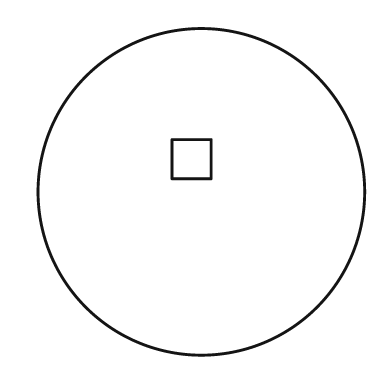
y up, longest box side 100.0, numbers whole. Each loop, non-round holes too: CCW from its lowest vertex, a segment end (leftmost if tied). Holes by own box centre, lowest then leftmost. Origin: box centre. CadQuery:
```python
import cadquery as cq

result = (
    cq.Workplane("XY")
    .moveTo(0.0, 0.0)
    .circle(50.0)
    .moveTo(-9.0, 4.0)
    .lineTo(3.0, 4.0)
    .lineTo(3.0, 16.0)
    .lineTo(-9.0, 16.0)
    .close()
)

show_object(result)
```